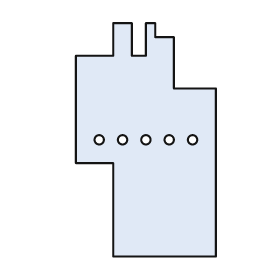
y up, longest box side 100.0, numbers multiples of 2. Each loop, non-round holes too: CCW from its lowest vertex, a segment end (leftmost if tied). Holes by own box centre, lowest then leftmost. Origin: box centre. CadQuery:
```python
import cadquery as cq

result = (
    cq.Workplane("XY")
    .moveTo(-14.0, -50.0)
    .lineTo(30.0, -50.0)
    .lineTo(30.0, 22.0)
    .lineTo(12.0, 22.0)
    .lineTo(12.0, 44.0)
    .lineTo(4.0, 44.0)
    .lineTo(4.0, 50.0)
    .lineTo(0.0, 50.0)
    .lineTo(0.0, 36.0)
    .lineTo(-6.0, 36.0)
    .lineTo(-6.0, 50.0)
    .lineTo(-14.0, 50.0)
    .lineTo(-14.0, 36.0)
    .lineTo(-30.0, 36.0)
    .lineTo(-30.0, -10.0)
    .lineTo(-14.0, -10.0)
    .close()
    .moveTo(-20.0, 0.0)
    .circle(2.0)
    .moveTo(-10.0, 0.0)
    .circle(2.0)
    .moveTo(0.0, 0.0)
    .circle(2.0)
    .moveTo(10.0, 0.0)
    .circle(2.0)
    .moveTo(20.0, 0.0)
    .circle(2.0)
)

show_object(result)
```